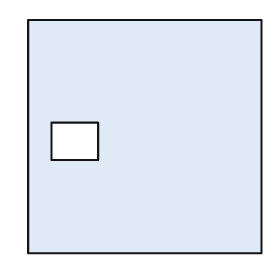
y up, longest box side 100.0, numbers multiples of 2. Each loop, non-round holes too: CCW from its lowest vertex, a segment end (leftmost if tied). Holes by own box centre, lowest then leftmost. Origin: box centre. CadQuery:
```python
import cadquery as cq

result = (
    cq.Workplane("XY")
    .moveTo(-50.0, -50.0)
    .lineTo(50.0, -50.0)
    .lineTo(50.0, 50.0)
    .lineTo(-50.0, 50.0)
    .close()
    .moveTo(-40.0, -10.0)
    .lineTo(-20.0, -10.0)
    .lineTo(-20.0, 6.0)
    .lineTo(-40.0, 6.0)
    .close()
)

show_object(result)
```